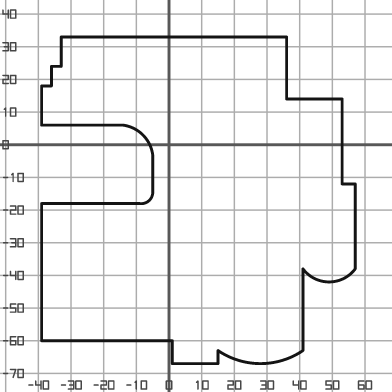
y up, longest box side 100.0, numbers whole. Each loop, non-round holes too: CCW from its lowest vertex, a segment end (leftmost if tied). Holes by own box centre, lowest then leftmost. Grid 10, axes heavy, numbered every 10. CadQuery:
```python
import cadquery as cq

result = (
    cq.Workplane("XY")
    .moveTo(1.0, -67.0)
    .lineTo(15.0, -67.0)
    .lineTo(15.0, -63.0)
    .threePointArc((28.0, -67.0), (41.0, -63.0))
    .lineTo(41.0, -38.0)
    .threePointArc((49.0, -42.0), (57.0, -38.0))
    .lineTo(57.0, -12.0)
    .lineTo(53.0, -12.0)
    .lineTo(53.0, 14.0)
    .lineTo(36.0, 14.0)
    .lineTo(36.0, 33.0)
    .lineTo(-33.0, 33.0)
    .lineTo(-33.0, 24.0)
    .lineTo(-36.0, 24.0)
    .lineTo(-36.0, 18.0)
    .lineTo(-39.0, 18.0)
    .lineTo(-39.0, 6.0)
    .lineTo(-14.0, 6.0)
    .threePointArc((-8.0, 3.0), (-5.0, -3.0))
    .lineTo(-5.0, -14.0)
    .threePointArc((-6.0, -17.0), (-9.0, -18.0))
    .lineTo(-39.0, -18.0)
    .lineTo(-39.0, -60.0)
    .lineTo(1.0, -60.0)
    .close()
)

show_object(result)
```